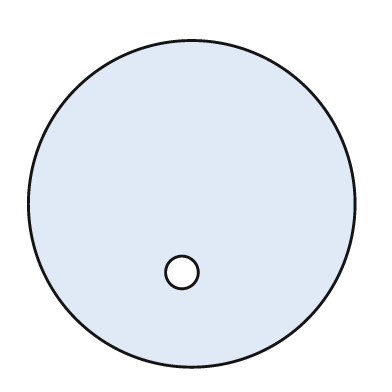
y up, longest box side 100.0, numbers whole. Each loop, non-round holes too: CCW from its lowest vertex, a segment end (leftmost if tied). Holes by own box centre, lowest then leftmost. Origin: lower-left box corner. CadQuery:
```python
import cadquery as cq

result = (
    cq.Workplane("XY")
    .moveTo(50.0, 50.0)
    .circle(50.0)
    .moveTo(47.0, 29.0)
    .circle(5.0)
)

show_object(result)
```